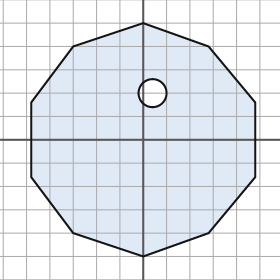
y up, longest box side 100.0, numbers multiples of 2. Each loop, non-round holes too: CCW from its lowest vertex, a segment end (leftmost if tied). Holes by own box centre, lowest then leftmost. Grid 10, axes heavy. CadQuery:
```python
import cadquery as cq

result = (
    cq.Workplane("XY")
    .moveTo(0.0, -50.0)
    .lineTo(28.0, -40.0)
    .lineTo(48.0, -16.0)
    .lineTo(48.0, 16.0)
    .lineTo(28.0, 40.0)
    .lineTo(0.0, 50.0)
    .lineTo(-30.0, 40.0)
    .lineTo(-48.0, 16.0)
    .lineTo(-48.0, -16.0)
    .lineTo(-30.0, -40.0)
    .close()
    .moveTo(4.0, 20.0)
    .circle(6.0)
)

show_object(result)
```